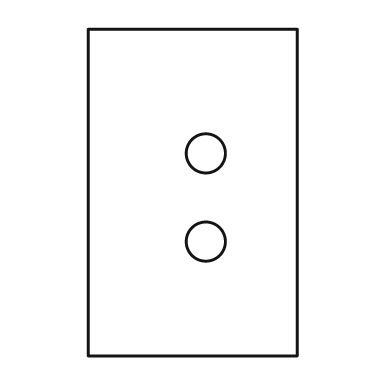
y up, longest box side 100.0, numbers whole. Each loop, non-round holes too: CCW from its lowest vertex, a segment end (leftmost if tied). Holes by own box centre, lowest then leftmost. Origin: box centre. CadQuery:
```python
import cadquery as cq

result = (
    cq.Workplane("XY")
    .moveTo(-32.0, -50.0)
    .lineTo(32.0, -50.0)
    .lineTo(32.0, 50.0)
    .lineTo(-32.0, 50.0)
    .close()
    .moveTo(4.0, -15.0)
    .circle(6.0)
    .moveTo(4.0, 12.0)
    .circle(6.0)
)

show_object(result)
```